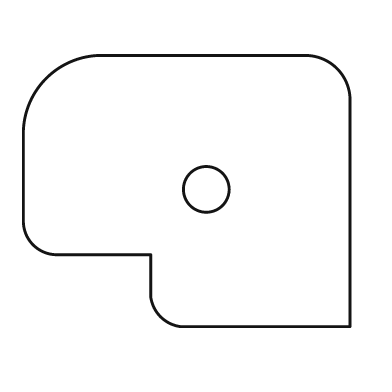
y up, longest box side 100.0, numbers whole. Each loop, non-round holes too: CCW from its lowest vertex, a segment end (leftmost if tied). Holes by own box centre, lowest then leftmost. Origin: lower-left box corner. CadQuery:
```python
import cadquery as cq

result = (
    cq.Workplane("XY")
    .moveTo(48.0, 0.0)
    .lineTo(100.0, 0.0)
    .lineTo(100.0, 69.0)
    .threePointArc((96.0, 79.0), (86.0, 83.0))
    .lineTo(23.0, 83.0)
    .threePointArc((7.0, 76.0), (0.0, 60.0))
    .lineTo(0.0, 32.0)
    .threePointArc((3.0, 25.0), (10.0, 22.0))
    .lineTo(39.0, 22.0)
    .lineTo(39.0, 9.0)
    .threePointArc((42.0, 3.0), (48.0, 0.0))
    .close()
    .moveTo(56.0, 42.0)
    .circle(7.0)
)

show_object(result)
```